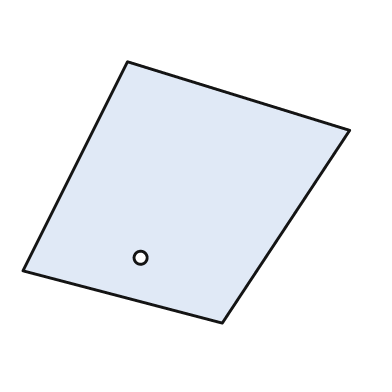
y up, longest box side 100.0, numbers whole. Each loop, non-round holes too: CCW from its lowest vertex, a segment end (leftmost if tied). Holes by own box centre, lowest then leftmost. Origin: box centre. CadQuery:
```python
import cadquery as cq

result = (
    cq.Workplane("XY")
    .moveTo(11.0, -40.0)
    .lineTo(50.0, 19.0)
    .lineTo(-18.0, 40.0)
    .lineTo(-50.0, -24.0)
    .close()
    .moveTo(-14.0, -20.0)
    .circle(2.0)
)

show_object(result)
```